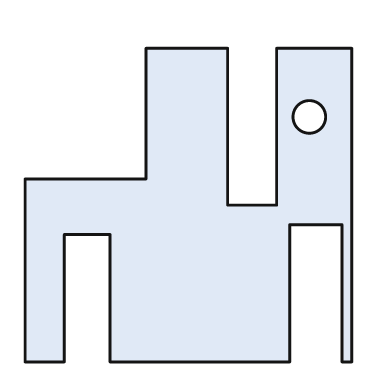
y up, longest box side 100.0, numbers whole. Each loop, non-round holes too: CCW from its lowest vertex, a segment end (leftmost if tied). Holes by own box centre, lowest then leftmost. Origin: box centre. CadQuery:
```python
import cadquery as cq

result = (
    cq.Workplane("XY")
    .moveTo(-50.0, -48.0)
    .lineTo(-38.0, -48.0)
    .lineTo(-38.0, -9.0)
    .lineTo(-24.0, -9.0)
    .lineTo(-24.0, -48.0)
    .lineTo(31.0, -48.0)
    .lineTo(31.0, -6.0)
    .lineTo(47.0, -6.0)
    .lineTo(47.0, -48.0)
    .lineTo(50.0, -48.0)
    .lineTo(50.0, 48.0)
    .lineTo(27.0, 48.0)
    .lineTo(27.0, 0.0)
    .lineTo(12.0, 0.0)
    .lineTo(12.0, 48.0)
    .lineTo(-13.0, 48.0)
    .lineTo(-13.0, 8.0)
    .lineTo(-50.0, 8.0)
    .close()
    .moveTo(37.0, 27.0)
    .circle(5.0)
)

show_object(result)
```